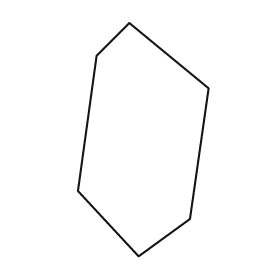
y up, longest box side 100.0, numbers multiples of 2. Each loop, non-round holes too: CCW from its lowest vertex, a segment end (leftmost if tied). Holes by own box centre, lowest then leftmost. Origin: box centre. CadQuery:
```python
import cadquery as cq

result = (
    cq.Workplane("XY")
    .moveTo(-2.0, -50.0)
    .lineTo(20.0, -34.0)
    .lineTo(28.0, 22.0)
    .lineTo(-6.0, 50.0)
    .lineTo(-20.0, 36.0)
    .lineTo(-28.0, -22.0)
    .close()
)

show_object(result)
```